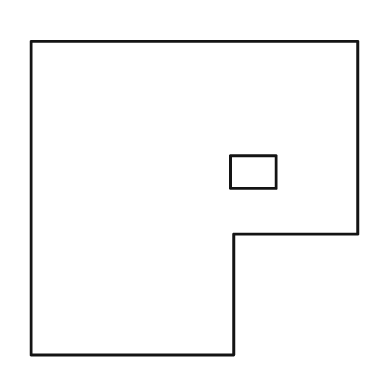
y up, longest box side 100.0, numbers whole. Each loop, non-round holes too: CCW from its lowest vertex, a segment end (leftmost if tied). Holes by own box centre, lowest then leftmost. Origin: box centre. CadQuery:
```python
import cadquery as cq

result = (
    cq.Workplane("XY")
    .moveTo(-50.0, -48.0)
    .lineTo(12.0, -48.0)
    .lineTo(12.0, -11.0)
    .lineTo(50.0, -11.0)
    .lineTo(50.0, 48.0)
    .lineTo(-50.0, 48.0)
    .close()
    .moveTo(11.0, 3.0)
    .lineTo(25.0, 3.0)
    .lineTo(25.0, 13.0)
    .lineTo(11.0, 13.0)
    .close()
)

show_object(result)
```